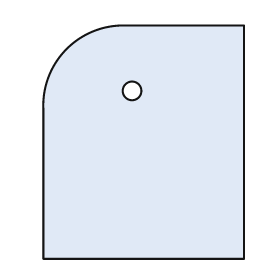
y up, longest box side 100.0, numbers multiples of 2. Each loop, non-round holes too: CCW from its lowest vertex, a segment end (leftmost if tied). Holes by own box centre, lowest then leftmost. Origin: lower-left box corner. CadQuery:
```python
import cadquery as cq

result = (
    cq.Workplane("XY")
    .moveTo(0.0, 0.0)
    .lineTo(86.0, 0.0)
    .lineTo(86.0, 100.0)
    .lineTo(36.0, 100.0)
    .threePointArc((10.0, 90.0), (0.0, 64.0))
    .close()
    .moveTo(38.0, 72.0)
    .circle(4.0)
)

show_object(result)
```